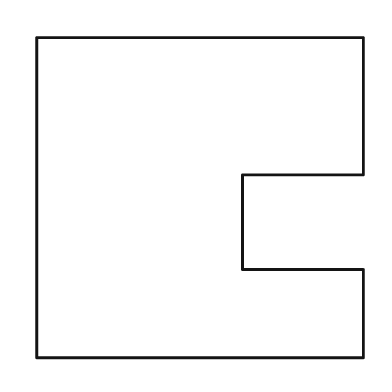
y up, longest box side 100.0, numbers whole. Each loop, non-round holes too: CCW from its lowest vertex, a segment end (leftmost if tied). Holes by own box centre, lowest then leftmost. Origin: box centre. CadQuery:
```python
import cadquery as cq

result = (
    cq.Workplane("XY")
    .moveTo(-50.0, -49.0)
    .lineTo(50.0, -49.0)
    .lineTo(50.0, -22.0)
    .lineTo(13.0, -22.0)
    .lineTo(13.0, 7.0)
    .lineTo(50.0, 7.0)
    .lineTo(50.0, 49.0)
    .lineTo(-50.0, 49.0)
    .close()
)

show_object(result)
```